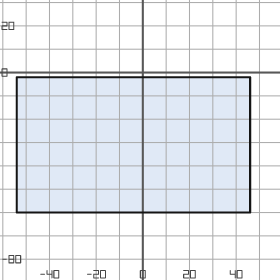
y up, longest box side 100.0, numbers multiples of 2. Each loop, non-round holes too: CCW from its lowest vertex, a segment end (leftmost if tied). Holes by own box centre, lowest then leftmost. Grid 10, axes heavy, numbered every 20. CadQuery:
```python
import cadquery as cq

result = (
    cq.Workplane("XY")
    .moveTo(-54.0, -60.0)
    .lineTo(46.0, -60.0)
    .lineTo(46.0, -2.0)
    .lineTo(-54.0, -2.0)
    .close()
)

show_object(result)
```